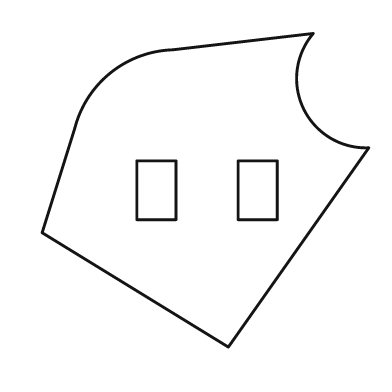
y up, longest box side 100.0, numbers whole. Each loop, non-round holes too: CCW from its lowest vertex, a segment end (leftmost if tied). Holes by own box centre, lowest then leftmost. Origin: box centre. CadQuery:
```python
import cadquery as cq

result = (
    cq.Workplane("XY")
    .moveTo(7.0, -48.0)
    .lineTo(50.0, 13.0)
    .threePointArc((30.0, 25.0), (33.0, 48.0))
    .lineTo(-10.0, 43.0)
    .threePointArc((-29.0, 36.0), (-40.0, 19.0))
    .lineTo(-50.0, -13.0)
    .close()
    .moveTo(-21.0, -9.0)
    .lineTo(-9.0, -9.0)
    .lineTo(-9.0, 9.0)
    .lineTo(-21.0, 9.0)
    .close()
    .moveTo(10.0, -9.0)
    .lineTo(22.0, -9.0)
    .lineTo(22.0, 9.0)
    .lineTo(10.0, 9.0)
    .close()
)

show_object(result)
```